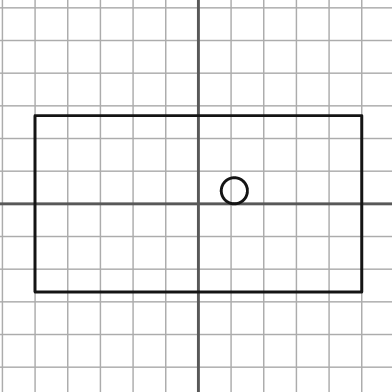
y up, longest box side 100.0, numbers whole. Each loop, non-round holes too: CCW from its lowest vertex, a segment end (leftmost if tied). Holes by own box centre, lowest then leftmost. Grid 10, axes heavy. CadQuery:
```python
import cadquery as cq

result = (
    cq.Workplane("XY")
    .moveTo(-50.0, -27.0)
    .lineTo(50.0, -27.0)
    .lineTo(50.0, 27.0)
    .lineTo(-50.0, 27.0)
    .close()
    .moveTo(11.0, 4.0)
    .circle(4.0)
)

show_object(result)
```